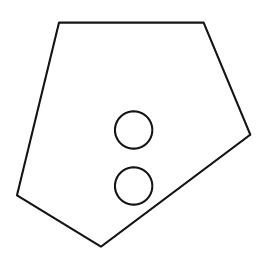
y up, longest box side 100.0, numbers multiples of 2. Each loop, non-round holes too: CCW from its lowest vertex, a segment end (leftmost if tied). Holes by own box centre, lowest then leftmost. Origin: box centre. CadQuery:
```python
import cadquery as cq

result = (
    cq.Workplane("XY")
    .moveTo(-14.0, -48.0)
    .lineTo(50.0, 0.0)
    .lineTo(30.0, 48.0)
    .lineTo(-32.0, 48.0)
    .lineTo(-50.0, -26.0)
    .close()
    .moveTo(0.0, -22.0)
    .circle(8.0)
    .moveTo(0.0, 2.0)
    .circle(8.0)
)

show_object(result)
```